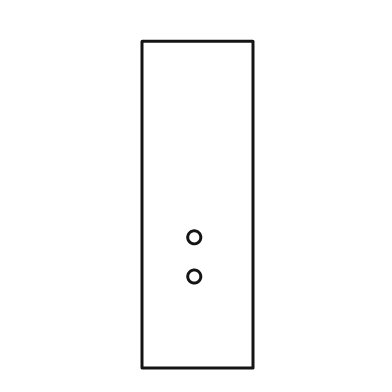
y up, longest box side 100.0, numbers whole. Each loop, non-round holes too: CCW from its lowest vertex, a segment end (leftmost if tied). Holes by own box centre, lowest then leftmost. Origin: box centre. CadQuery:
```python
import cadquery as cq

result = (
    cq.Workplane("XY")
    .moveTo(-17.0, -50.0)
    .lineTo(17.0, -50.0)
    .lineTo(17.0, 50.0)
    .lineTo(-17.0, 50.0)
    .close()
    .moveTo(-1.0, -22.0)
    .circle(2.0)
    .moveTo(-1.0, -10.0)
    .circle(2.0)
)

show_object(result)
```